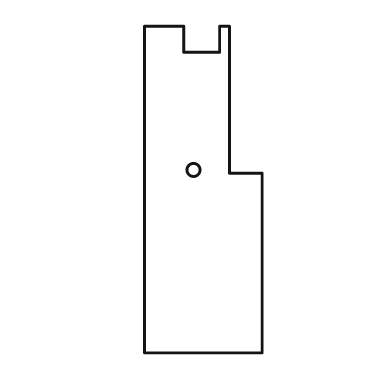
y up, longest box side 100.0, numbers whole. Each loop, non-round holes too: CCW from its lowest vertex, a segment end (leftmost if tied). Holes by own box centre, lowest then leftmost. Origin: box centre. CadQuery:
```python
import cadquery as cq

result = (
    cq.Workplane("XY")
    .moveTo(-18.0, -50.0)
    .lineTo(18.0, -50.0)
    .lineTo(18.0, 5.0)
    .lineTo(8.0, 5.0)
    .lineTo(8.0, 50.0)
    .lineTo(5.0, 50.0)
    .lineTo(5.0, 42.0)
    .lineTo(-6.0, 42.0)
    .lineTo(-6.0, 50.0)
    .lineTo(-18.0, 50.0)
    .close()
    .moveTo(-3.0, 6.0)
    .circle(2.0)
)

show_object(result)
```